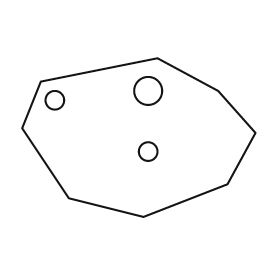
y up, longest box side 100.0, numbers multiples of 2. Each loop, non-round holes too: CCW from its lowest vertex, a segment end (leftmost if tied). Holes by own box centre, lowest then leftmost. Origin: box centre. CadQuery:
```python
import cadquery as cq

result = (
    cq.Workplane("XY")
    .moveTo(2.0, -34.0)
    .lineTo(38.0, -20.0)
    .lineTo(50.0, 2.0)
    .lineTo(34.0, 20.0)
    .lineTo(8.0, 34.0)
    .lineTo(-42.0, 24.0)
    .lineTo(-50.0, 4.0)
    .lineTo(-30.0, -26.0)
    .close()
    .moveTo(4.0, -6.0)
    .circle(4.0)
    .moveTo(-36.0, 16.0)
    .circle(4.0)
    .moveTo(4.0, 20.0)
    .circle(6.0)
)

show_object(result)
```